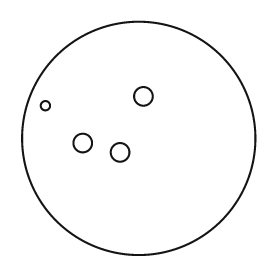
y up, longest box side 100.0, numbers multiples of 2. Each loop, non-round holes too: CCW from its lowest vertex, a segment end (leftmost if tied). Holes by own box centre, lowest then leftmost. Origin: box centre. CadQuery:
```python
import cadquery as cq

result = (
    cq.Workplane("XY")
    .moveTo(0.0, 0.0)
    .circle(50.0)
    .moveTo(-8.0, -6.0)
    .circle(4.0)
    .moveTo(-24.0, -2.0)
    .circle(4.0)
    .moveTo(-40.0, 14.0)
    .circle(2.0)
    .moveTo(2.0, 18.0)
    .circle(4.0)
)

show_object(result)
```